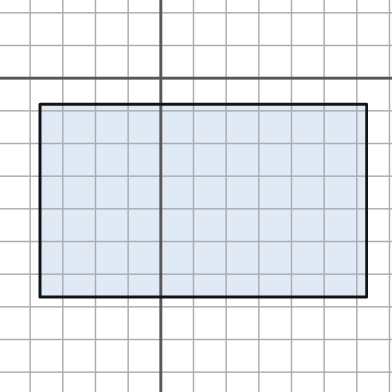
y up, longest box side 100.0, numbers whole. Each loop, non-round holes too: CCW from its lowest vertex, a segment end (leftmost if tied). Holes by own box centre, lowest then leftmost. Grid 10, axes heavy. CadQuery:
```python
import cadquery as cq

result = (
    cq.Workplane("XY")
    .moveTo(-37.0, -67.0)
    .lineTo(63.0, -67.0)
    .lineTo(63.0, -8.0)
    .lineTo(-37.0, -8.0)
    .close()
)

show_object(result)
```